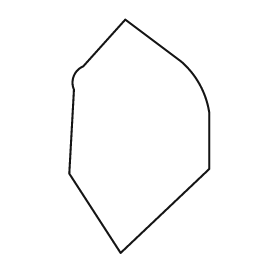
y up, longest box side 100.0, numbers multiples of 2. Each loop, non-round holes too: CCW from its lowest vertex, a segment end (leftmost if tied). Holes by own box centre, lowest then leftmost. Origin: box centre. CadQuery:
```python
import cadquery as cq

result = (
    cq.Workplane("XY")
    .moveTo(-8.0, -50.0)
    .lineTo(30.0, -14.0)
    .lineTo(30.0, 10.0)
    .threePointArc((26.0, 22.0), (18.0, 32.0))
    .lineTo(-6.0, 50.0)
    .lineTo(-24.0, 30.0)
    .threePointArc((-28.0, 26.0), (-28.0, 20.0))
    .lineTo(-30.0, -16.0)
    .close()
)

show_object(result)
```